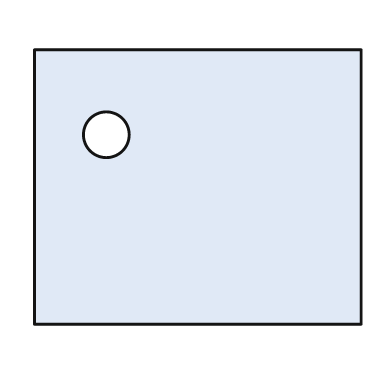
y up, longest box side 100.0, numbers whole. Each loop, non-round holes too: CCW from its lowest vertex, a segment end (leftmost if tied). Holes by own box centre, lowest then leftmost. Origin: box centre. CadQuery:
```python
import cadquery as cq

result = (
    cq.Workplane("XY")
    .moveTo(-50.0, -42.0)
    .lineTo(50.0, -42.0)
    .lineTo(50.0, 42.0)
    .lineTo(-50.0, 42.0)
    .close()
    .moveTo(-28.0, 16.0)
    .circle(7.0)
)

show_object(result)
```